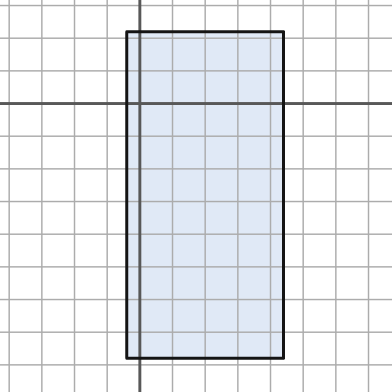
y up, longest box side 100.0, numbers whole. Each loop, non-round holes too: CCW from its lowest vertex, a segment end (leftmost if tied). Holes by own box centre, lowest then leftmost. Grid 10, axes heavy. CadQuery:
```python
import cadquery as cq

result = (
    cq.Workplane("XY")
    .moveTo(-4.0, -78.0)
    .lineTo(44.0, -78.0)
    .lineTo(44.0, 22.0)
    .lineTo(-4.0, 22.0)
    .close()
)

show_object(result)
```